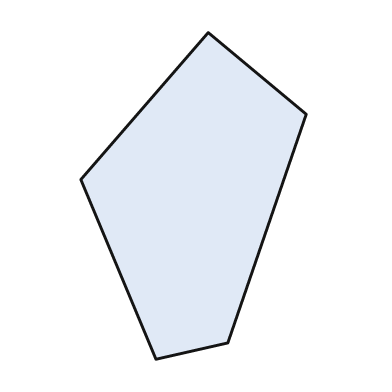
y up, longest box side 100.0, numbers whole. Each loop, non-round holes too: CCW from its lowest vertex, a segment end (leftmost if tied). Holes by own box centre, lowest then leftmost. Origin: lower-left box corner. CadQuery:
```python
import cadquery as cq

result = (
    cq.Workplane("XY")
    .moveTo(23.0, 0.0)
    .lineTo(45.0, 5.0)
    .lineTo(69.0, 75.0)
    .lineTo(39.0, 100.0)
    .lineTo(0.0, 55.0)
    .close()
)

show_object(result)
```